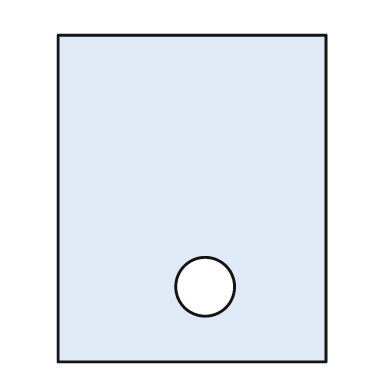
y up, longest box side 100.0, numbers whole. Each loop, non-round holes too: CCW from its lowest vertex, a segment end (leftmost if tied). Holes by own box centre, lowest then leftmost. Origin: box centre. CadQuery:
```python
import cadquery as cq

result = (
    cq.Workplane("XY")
    .moveTo(-41.0, -50.0)
    .lineTo(41.0, -50.0)
    .lineTo(41.0, 50.0)
    .lineTo(-41.0, 50.0)
    .close()
    .moveTo(4.0, -27.0)
    .circle(9.0)
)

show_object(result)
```